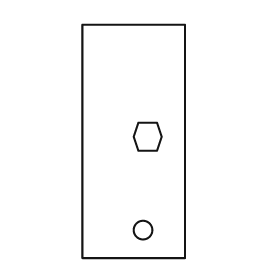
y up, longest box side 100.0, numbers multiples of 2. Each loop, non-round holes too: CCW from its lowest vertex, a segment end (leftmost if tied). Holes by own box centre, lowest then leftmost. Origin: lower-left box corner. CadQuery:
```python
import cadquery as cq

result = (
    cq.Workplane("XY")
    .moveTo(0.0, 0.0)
    .lineTo(44.0, 0.0)
    .lineTo(44.0, 100.0)
    .lineTo(0.0, 100.0)
    .close()
    .moveTo(26.0, 12.0)
    .circle(4.0)
    .moveTo(24.0, 46.0)
    .lineTo(32.0, 46.0)
    .lineTo(34.0, 52.0)
    .lineTo(32.0, 58.0)
    .lineTo(24.0, 58.0)
    .lineTo(22.0, 52.0)
    .close()
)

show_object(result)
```